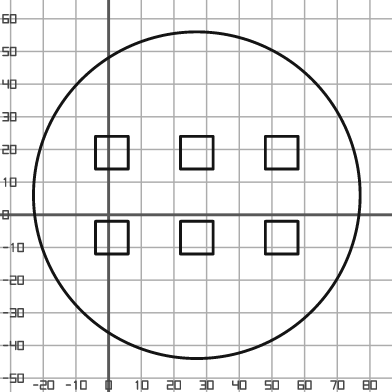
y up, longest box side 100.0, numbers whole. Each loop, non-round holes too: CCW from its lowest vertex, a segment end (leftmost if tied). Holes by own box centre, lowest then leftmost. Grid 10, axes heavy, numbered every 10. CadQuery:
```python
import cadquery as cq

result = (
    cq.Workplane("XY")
    .moveTo(27.0, 6.0)
    .circle(50.0)
    .moveTo(-4.0, -12.0)
    .lineTo(6.0, -12.0)
    .lineTo(6.0, -2.0)
    .lineTo(-4.0, -2.0)
    .close()
    .moveTo(22.0, -12.0)
    .lineTo(32.0, -12.0)
    .lineTo(32.0, -2.0)
    .lineTo(22.0, -2.0)
    .close()
    .moveTo(48.0, -12.0)
    .lineTo(58.0, -12.0)
    .lineTo(58.0, -2.0)
    .lineTo(48.0, -2.0)
    .close()
    .moveTo(-4.0, 14.0)
    .lineTo(6.0, 14.0)
    .lineTo(6.0, 24.0)
    .lineTo(-4.0, 24.0)
    .close()
    .moveTo(22.0, 14.0)
    .lineTo(32.0, 14.0)
    .lineTo(32.0, 24.0)
    .lineTo(22.0, 24.0)
    .close()
    .moveTo(48.0, 14.0)
    .lineTo(58.0, 14.0)
    .lineTo(58.0, 24.0)
    .lineTo(48.0, 24.0)
    .close()
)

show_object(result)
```